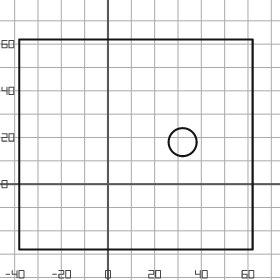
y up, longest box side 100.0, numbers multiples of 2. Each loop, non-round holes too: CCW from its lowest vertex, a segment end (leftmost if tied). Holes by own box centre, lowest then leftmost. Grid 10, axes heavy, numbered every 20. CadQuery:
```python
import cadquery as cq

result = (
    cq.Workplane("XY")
    .moveTo(-38.0, -28.0)
    .lineTo(62.0, -28.0)
    .lineTo(62.0, 62.0)
    .lineTo(-38.0, 62.0)
    .close()
    .moveTo(32.0, 18.0)
    .circle(6.0)
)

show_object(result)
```